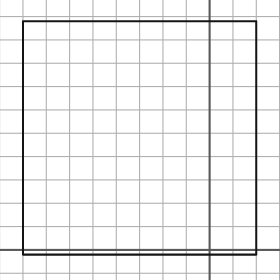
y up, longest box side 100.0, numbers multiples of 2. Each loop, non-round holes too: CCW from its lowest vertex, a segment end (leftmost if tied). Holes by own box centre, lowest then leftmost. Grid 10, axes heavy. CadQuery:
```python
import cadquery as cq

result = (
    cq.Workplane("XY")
    .moveTo(-80.0, -2.0)
    .lineTo(20.0, -2.0)
    .lineTo(20.0, 98.0)
    .lineTo(-80.0, 98.0)
    .close()
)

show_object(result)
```